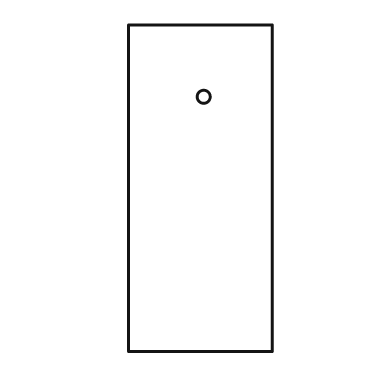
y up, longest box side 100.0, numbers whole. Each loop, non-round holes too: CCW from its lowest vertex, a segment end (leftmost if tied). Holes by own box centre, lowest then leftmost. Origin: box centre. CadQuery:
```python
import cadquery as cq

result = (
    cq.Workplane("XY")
    .moveTo(-22.0, -50.0)
    .lineTo(22.0, -50.0)
    .lineTo(22.0, 50.0)
    .lineTo(-22.0, 50.0)
    .close()
    .moveTo(1.0, 28.0)
    .circle(2.0)
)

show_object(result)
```